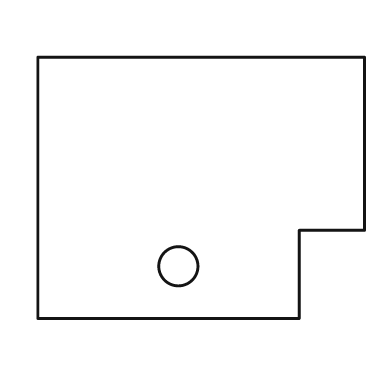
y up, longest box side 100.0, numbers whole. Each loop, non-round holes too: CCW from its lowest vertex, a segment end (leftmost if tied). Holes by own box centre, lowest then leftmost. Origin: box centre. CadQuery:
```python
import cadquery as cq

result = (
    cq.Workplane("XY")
    .moveTo(-50.0, -40.0)
    .lineTo(30.0, -40.0)
    .lineTo(30.0, -13.0)
    .lineTo(50.0, -13.0)
    .lineTo(50.0, 40.0)
    .lineTo(-50.0, 40.0)
    .close()
    .moveTo(-7.0, -24.0)
    .circle(6.0)
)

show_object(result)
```